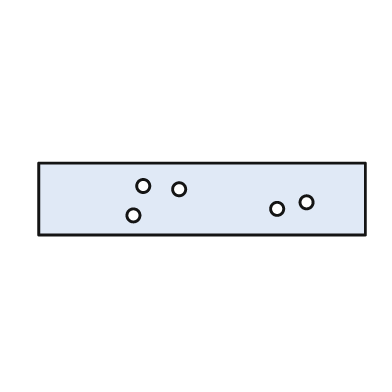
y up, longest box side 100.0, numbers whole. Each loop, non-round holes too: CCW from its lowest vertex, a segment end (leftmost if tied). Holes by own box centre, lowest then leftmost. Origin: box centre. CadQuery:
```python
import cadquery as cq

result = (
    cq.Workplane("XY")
    .moveTo(-50.0, -11.0)
    .lineTo(50.0, -11.0)
    .lineTo(50.0, 11.0)
    .lineTo(-50.0, 11.0)
    .close()
    .moveTo(-21.0, -5.0)
    .circle(2.0)
    .moveTo(23.0, -3.0)
    .circle(2.0)
    .moveTo(32.0, -1.0)
    .circle(2.0)
    .moveTo(-7.0, 3.0)
    .circle(2.0)
    .moveTo(-18.0, 4.0)
    .circle(2.0)
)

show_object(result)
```